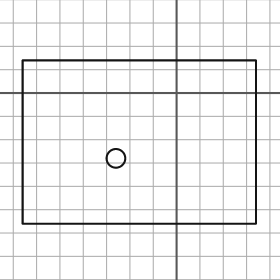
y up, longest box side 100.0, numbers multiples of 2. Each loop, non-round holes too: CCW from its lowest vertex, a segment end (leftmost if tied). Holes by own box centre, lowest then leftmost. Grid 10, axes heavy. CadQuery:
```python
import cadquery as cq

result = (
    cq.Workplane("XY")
    .moveTo(-66.0, -56.0)
    .lineTo(34.0, -56.0)
    .lineTo(34.0, 14.0)
    .lineTo(-66.0, 14.0)
    .close()
    .moveTo(-26.0, -28.0)
    .circle(4.0)
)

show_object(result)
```